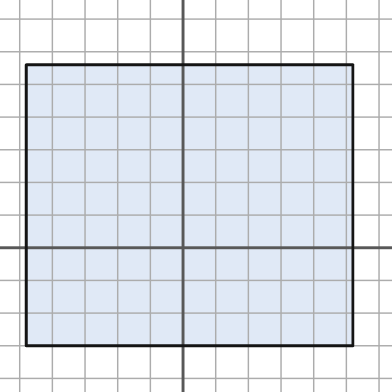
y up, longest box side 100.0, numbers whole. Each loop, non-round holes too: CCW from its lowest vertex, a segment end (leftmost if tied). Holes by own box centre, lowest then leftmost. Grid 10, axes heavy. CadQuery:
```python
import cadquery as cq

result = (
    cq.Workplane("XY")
    .moveTo(-48.0, -30.0)
    .lineTo(52.0, -30.0)
    .lineTo(52.0, 56.0)
    .lineTo(-48.0, 56.0)
    .close()
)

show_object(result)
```